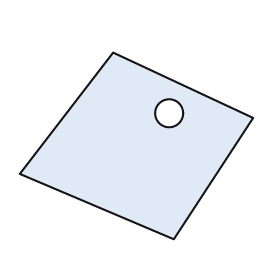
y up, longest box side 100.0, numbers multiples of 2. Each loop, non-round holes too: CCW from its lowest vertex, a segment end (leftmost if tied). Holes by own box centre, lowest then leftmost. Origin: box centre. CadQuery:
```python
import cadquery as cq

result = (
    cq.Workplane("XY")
    .moveTo(16.0, -40.0)
    .lineTo(50.0, 12.0)
    .lineTo(-10.0, 40.0)
    .lineTo(-50.0, -12.0)
    .close()
    .moveTo(14.0, 14.0)
    .circle(6.0)
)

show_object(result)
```